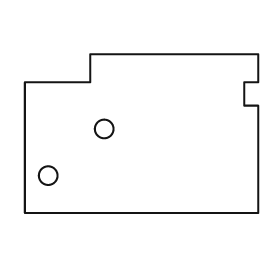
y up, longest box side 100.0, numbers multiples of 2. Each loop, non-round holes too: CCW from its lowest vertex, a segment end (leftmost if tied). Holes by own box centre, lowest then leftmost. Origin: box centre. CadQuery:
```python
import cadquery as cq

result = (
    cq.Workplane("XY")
    .moveTo(-50.0, -34.0)
    .lineTo(50.0, -34.0)
    .lineTo(50.0, 12.0)
    .lineTo(44.0, 12.0)
    .lineTo(44.0, 22.0)
    .lineTo(50.0, 22.0)
    .lineTo(50.0, 34.0)
    .lineTo(-22.0, 34.0)
    .lineTo(-22.0, 22.0)
    .lineTo(-50.0, 22.0)
    .close()
    .moveTo(-40.0, -18.0)
    .circle(4.0)
    .moveTo(-16.0, 2.0)
    .circle(4.0)
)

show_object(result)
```